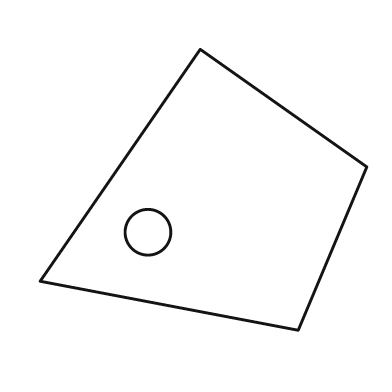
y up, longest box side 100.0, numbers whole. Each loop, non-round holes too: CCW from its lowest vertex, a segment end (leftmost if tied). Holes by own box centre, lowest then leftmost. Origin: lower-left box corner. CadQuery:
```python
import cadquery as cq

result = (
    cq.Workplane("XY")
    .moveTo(79.0, 0.0)
    .lineTo(100.0, 50.0)
    .lineTo(49.0, 86.0)
    .lineTo(0.0, 15.0)
    .close()
    .moveTo(33.0, 30.0)
    .circle(7.0)
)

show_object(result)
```